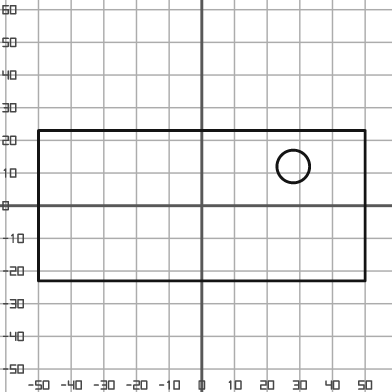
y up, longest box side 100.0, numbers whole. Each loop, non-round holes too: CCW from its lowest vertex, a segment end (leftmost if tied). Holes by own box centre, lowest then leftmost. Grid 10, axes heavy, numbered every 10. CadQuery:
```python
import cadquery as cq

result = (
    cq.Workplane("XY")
    .moveTo(-50.0, -23.0)
    .lineTo(50.0, -23.0)
    .lineTo(50.0, 23.0)
    .lineTo(-50.0, 23.0)
    .close()
    .moveTo(28.0, 12.0)
    .circle(5.0)
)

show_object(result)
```